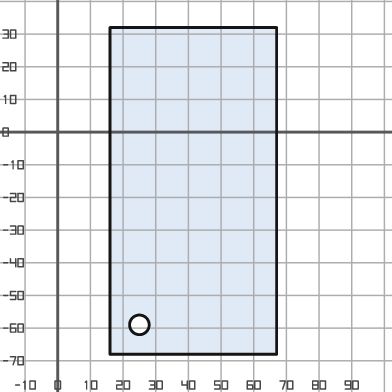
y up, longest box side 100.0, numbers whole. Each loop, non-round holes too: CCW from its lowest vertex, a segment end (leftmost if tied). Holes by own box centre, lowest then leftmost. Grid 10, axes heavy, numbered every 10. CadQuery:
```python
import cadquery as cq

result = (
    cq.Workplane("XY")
    .moveTo(16.0, -68.0)
    .lineTo(67.0, -68.0)
    .lineTo(67.0, 32.0)
    .lineTo(16.0, 32.0)
    .close()
    .moveTo(25.0, -59.0)
    .circle(3.0)
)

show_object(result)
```